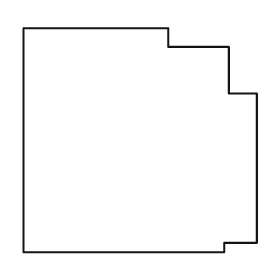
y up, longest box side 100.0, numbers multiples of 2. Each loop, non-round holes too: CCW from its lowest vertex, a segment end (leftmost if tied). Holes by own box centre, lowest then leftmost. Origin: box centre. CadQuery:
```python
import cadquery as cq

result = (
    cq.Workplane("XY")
    .moveTo(-50.0, -48.0)
    .lineTo(36.0, -48.0)
    .lineTo(36.0, -44.0)
    .lineTo(50.0, -44.0)
    .lineTo(50.0, 20.0)
    .lineTo(38.0, 20.0)
    .lineTo(38.0, 40.0)
    .lineTo(12.0, 40.0)
    .lineTo(12.0, 48.0)
    .lineTo(-50.0, 48.0)
    .close()
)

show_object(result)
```